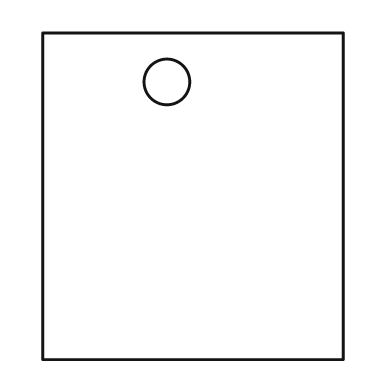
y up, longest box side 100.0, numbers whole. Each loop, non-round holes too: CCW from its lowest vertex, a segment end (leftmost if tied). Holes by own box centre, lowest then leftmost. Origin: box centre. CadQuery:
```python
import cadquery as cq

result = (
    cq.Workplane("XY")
    .moveTo(-46.0, -50.0)
    .lineTo(46.0, -50.0)
    .lineTo(46.0, 50.0)
    .lineTo(-46.0, 50.0)
    .close()
    .moveTo(-8.0, 35.0)
    .circle(7.0)
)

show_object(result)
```